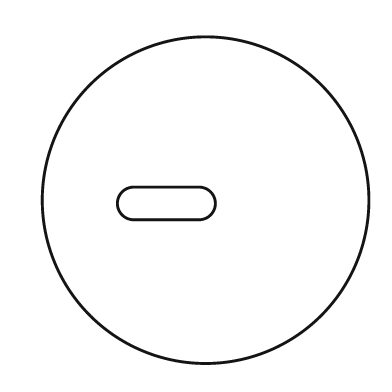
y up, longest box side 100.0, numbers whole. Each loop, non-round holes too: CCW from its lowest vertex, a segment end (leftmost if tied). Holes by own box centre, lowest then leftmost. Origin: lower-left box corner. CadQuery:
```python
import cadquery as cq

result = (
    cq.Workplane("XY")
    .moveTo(50.0, 50.0)
    .circle(50.0)
    .moveTo(28.0, 44.0)
    .lineTo(48.0, 44.0)
    .threePointArc((53.0, 49.0), (48.0, 54.0))
    .lineTo(28.0, 54.0)
    .threePointArc((23.0, 49.0), (28.0, 44.0))
    .close()
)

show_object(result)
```